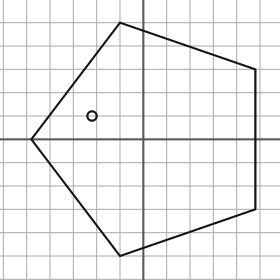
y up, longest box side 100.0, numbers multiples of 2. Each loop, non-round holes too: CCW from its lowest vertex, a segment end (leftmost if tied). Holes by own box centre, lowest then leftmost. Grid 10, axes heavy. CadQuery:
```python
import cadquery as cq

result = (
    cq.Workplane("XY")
    .moveTo(-10.0, -50.0)
    .lineTo(48.0, -30.0)
    .lineTo(48.0, 30.0)
    .lineTo(-10.0, 50.0)
    .lineTo(-48.0, 0.0)
    .close()
    .moveTo(-22.0, 10.0)
    .circle(2.0)
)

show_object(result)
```